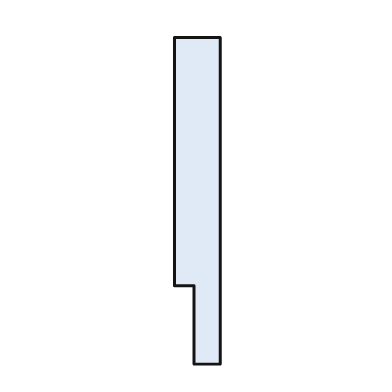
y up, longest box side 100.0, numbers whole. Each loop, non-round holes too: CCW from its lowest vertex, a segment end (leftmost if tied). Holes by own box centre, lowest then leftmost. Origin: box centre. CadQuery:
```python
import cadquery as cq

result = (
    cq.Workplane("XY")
    .moveTo(-1.0, -50.0)
    .lineTo(7.0, -50.0)
    .lineTo(7.0, 50.0)
    .lineTo(-7.0, 50.0)
    .lineTo(-7.0, -26.0)
    .lineTo(-1.0, -26.0)
    .close()
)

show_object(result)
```